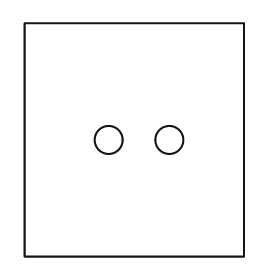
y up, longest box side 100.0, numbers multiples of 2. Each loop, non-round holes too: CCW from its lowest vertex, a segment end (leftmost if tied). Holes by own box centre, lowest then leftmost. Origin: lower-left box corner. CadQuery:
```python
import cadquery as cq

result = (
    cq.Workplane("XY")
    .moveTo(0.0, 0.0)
    .lineTo(94.0, 0.0)
    .lineTo(94.0, 100.0)
    .lineTo(0.0, 100.0)
    .close()
    .moveTo(36.0, 50.0)
    .circle(6.0)
    .moveTo(62.0, 50.0)
    .circle(6.0)
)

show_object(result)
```